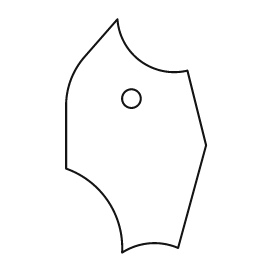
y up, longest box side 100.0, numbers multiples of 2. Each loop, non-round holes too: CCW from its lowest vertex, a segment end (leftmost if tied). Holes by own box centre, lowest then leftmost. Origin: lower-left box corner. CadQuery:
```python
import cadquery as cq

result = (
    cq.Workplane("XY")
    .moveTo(24.0, 0.0)
    .threePointArc((36.0, 4.0), (48.0, 2.0))
    .lineTo(60.0, 46.0)
    .lineTo(52.0, 78.0)
    .threePointArc((32.0, 82.0), (22.0, 100.0))
    .lineTo(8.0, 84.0)
    .threePointArc((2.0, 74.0), (0.0, 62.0))
    .lineTo(0.0, 36.0)
    .threePointArc((18.0, 22.0), (24.0, 0.0))
    .close()
    .moveTo(28.0, 66.0)
    .circle(4.0)
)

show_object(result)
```